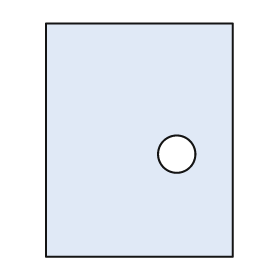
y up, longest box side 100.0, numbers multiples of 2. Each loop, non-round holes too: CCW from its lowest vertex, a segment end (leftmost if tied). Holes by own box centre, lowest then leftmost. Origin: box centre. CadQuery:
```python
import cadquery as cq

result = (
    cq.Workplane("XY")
    .moveTo(-40.0, -50.0)
    .lineTo(40.0, -50.0)
    .lineTo(40.0, 50.0)
    .lineTo(-40.0, 50.0)
    .close()
    .moveTo(16.0, -6.0)
    .circle(8.0)
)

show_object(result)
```